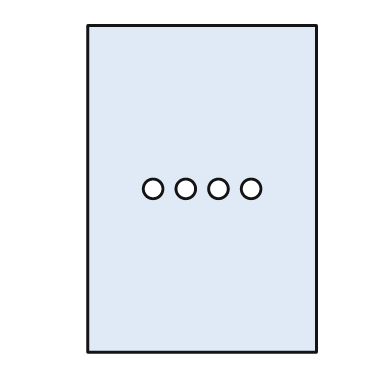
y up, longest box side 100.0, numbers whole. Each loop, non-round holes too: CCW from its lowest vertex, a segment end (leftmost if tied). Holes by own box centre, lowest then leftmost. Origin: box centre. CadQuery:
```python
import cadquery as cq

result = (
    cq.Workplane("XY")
    .moveTo(-35.0, -50.0)
    .lineTo(35.0, -50.0)
    .lineTo(35.0, 50.0)
    .lineTo(-35.0, 50.0)
    .close()
    .moveTo(-15.0, 0.0)
    .circle(3.0)
    .moveTo(-5.0, 0.0)
    .circle(3.0)
    .moveTo(5.0, 0.0)
    .circle(3.0)
    .moveTo(15.0, 0.0)
    .circle(3.0)
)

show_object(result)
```